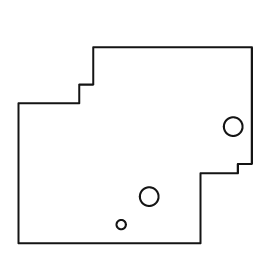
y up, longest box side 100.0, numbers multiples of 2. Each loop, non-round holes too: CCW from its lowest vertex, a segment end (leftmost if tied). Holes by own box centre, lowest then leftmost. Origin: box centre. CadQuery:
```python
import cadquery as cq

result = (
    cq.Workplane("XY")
    .moveTo(-50.0, -42.0)
    .lineTo(28.0, -42.0)
    .lineTo(28.0, -12.0)
    .lineTo(44.0, -12.0)
    .lineTo(44.0, -8.0)
    .lineTo(50.0, -8.0)
    .lineTo(50.0, 42.0)
    .lineTo(-18.0, 42.0)
    .lineTo(-18.0, 26.0)
    .lineTo(-24.0, 26.0)
    .lineTo(-24.0, 18.0)
    .lineTo(-50.0, 18.0)
    .close()
    .moveTo(-6.0, -34.0)
    .circle(2.0)
    .moveTo(6.0, -22.0)
    .circle(4.0)
    .moveTo(42.0, 8.0)
    .circle(4.0)
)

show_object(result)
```